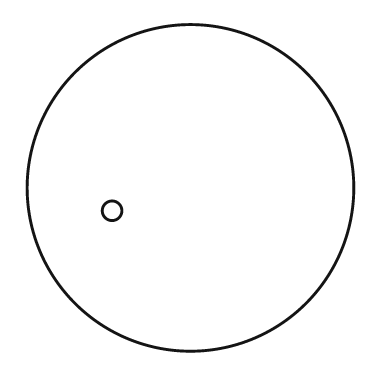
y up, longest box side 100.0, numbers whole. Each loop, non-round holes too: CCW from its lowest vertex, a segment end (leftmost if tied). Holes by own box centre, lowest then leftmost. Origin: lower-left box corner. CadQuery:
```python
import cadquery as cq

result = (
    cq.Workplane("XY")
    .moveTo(50.0, 50.0)
    .circle(50.0)
    .moveTo(26.0, 43.0)
    .circle(3.0)
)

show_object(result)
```